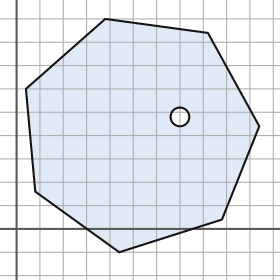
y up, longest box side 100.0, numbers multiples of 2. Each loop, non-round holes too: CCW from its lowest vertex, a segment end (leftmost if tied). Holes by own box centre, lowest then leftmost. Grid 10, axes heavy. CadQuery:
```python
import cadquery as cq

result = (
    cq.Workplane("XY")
    .moveTo(44.0, -10.0)
    .lineTo(88.0, 4.0)
    .lineTo(104.0, 44.0)
    .lineTo(82.0, 84.0)
    .lineTo(38.0, 90.0)
    .lineTo(4.0, 60.0)
    .lineTo(8.0, 16.0)
    .close()
    .moveTo(70.0, 48.0)
    .circle(4.0)
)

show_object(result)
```